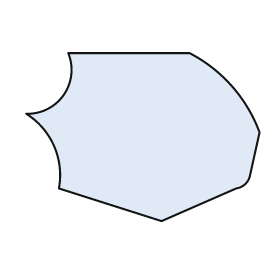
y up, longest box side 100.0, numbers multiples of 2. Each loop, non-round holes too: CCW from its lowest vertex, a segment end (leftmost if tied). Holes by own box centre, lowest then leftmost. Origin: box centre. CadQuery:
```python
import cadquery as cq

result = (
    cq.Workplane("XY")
    .moveTo(8.0, -36.0)
    .lineTo(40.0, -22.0)
    .threePointArc((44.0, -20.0), (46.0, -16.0))
    .lineTo(50.0, 2.0)
    .threePointArc((38.0, 22.0), (20.0, 36.0))
    .lineTo(-32.0, 36.0)
    .threePointArc((-34.0, 18.0), (-50.0, 10.0))
    .threePointArc((-38.0, -4.0), (-36.0, -22.0))
    .close()
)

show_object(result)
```